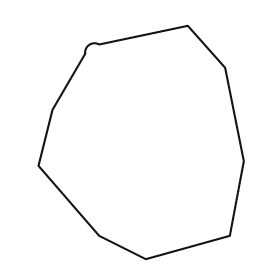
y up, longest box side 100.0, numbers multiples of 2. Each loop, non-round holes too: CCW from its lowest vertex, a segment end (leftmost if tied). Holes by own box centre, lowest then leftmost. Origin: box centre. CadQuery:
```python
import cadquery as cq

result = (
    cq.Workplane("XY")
    .moveTo(2.0, -50.0)
    .lineTo(38.0, -40.0)
    .lineTo(44.0, -8.0)
    .lineTo(36.0, 32.0)
    .lineTo(20.0, 50.0)
    .lineTo(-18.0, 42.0)
    .threePointArc((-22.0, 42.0), (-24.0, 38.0))
    .lineTo(-38.0, 14.0)
    .lineTo(-44.0, -10.0)
    .lineTo(-18.0, -40.0)
    .close()
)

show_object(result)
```